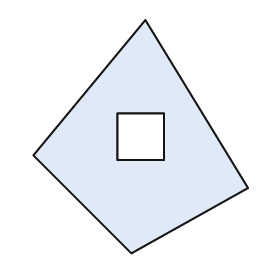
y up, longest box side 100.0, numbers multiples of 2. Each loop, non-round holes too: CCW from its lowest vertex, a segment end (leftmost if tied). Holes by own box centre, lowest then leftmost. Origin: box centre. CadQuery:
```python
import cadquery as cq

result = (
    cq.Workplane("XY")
    .moveTo(-4.0, -50.0)
    .lineTo(46.0, -22.0)
    .lineTo(2.0, 50.0)
    .lineTo(-46.0, -8.0)
    .close()
    .moveTo(-10.0, -10.0)
    .lineTo(10.0, -10.0)
    .lineTo(10.0, 10.0)
    .lineTo(-10.0, 10.0)
    .close()
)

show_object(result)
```